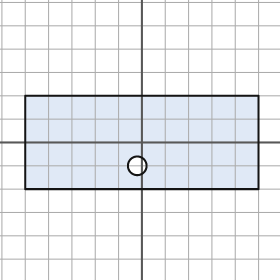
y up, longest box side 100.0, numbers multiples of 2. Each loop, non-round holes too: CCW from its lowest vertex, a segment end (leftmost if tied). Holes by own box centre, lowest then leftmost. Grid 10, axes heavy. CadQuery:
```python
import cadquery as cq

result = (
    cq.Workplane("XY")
    .moveTo(-50.0, -20.0)
    .lineTo(50.0, -20.0)
    .lineTo(50.0, 20.0)
    .lineTo(-50.0, 20.0)
    .close()
    .moveTo(-2.0, -10.0)
    .circle(4.0)
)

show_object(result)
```